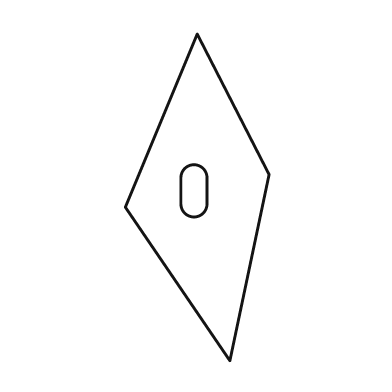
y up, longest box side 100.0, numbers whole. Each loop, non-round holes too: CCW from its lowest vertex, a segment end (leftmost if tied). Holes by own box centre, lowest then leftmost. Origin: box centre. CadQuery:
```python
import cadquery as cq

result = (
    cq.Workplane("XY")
    .moveTo(10.0, -50.0)
    .lineTo(22.0, 7.0)
    .lineTo(0.0, 50.0)
    .lineTo(-22.0, -3.0)
    .close()
    .moveTo(-5.0, -2.0)
    .threePointArc((-1.0, -6.0), (3.0, -2.0))
    .lineTo(3.0, 6.0)
    .threePointArc((-1.0, 10.0), (-5.0, 6.0))
    .close()
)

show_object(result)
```